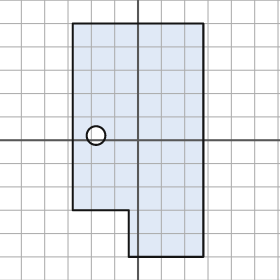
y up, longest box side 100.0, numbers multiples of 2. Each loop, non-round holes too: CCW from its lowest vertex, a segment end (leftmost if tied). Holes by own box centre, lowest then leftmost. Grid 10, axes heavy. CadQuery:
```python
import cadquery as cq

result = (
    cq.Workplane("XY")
    .moveTo(-4.0, -50.0)
    .lineTo(28.0, -50.0)
    .lineTo(28.0, 50.0)
    .lineTo(-28.0, 50.0)
    .lineTo(-28.0, -30.0)
    .lineTo(-4.0, -30.0)
    .close()
    .moveTo(-18.0, 2.0)
    .circle(4.0)
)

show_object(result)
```